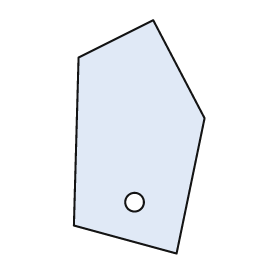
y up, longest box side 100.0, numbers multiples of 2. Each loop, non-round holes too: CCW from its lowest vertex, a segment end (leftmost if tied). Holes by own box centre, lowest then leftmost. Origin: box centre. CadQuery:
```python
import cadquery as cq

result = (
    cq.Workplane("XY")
    .moveTo(16.0, -50.0)
    .lineTo(28.0, 8.0)
    .lineTo(6.0, 50.0)
    .lineTo(-26.0, 34.0)
    .lineTo(-28.0, -38.0)
    .close()
    .moveTo(-2.0, -28.0)
    .circle(4.0)
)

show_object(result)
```